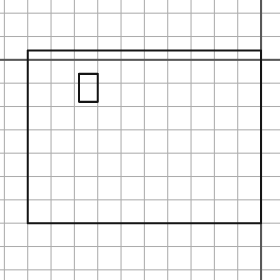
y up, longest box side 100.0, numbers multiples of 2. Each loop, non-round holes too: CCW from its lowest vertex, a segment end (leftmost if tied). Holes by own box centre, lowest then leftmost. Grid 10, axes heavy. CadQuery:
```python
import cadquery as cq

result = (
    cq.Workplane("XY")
    .moveTo(-100.0, -70.0)
    .lineTo(0.0, -70.0)
    .lineTo(0.0, 4.0)
    .lineTo(-100.0, 4.0)
    .close()
    .moveTo(-78.0, -18.0)
    .lineTo(-70.0, -18.0)
    .lineTo(-70.0, -6.0)
    .lineTo(-78.0, -6.0)
    .close()
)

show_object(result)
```